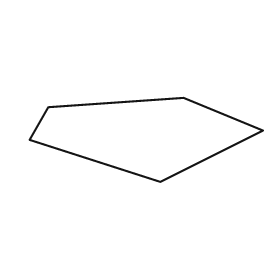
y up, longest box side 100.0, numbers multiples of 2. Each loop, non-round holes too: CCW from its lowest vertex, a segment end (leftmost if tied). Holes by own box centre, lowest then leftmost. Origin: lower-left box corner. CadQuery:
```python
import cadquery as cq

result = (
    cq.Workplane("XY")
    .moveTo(56.0, 0.0)
    .lineTo(100.0, 22.0)
    .lineTo(66.0, 36.0)
    .lineTo(8.0, 32.0)
    .lineTo(0.0, 18.0)
    .close()
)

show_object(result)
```